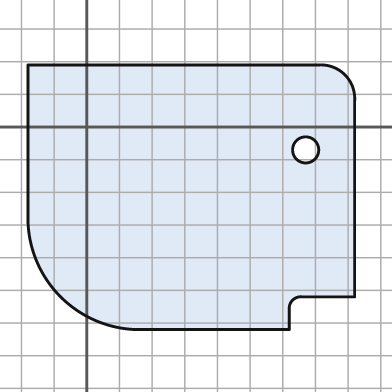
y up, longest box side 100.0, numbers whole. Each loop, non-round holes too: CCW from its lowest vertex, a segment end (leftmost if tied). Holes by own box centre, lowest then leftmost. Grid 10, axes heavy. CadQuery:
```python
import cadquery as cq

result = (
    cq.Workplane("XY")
    .moveTo(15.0, -62.0)
    .lineTo(62.0, -62.0)
    .lineTo(62.0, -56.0)
    .threePointArc((63.0, -53.0), (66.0, -52.0))
    .lineTo(82.0, -52.0)
    .lineTo(82.0, 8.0)
    .threePointArc((79.0, 16.0), (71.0, 19.0))
    .lineTo(-18.0, 19.0)
    .lineTo(-18.0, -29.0)
    .threePointArc((-8.0, -52.0), (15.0, -62.0))
    .close()
    .moveTo(67.0, -7.0)
    .circle(4.0)
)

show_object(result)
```